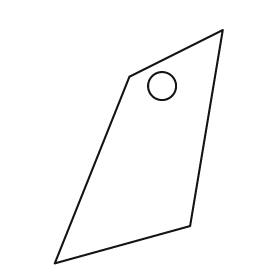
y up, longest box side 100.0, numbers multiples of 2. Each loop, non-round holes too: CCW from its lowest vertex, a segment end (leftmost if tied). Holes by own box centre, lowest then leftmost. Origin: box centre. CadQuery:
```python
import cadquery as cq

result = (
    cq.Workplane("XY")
    .moveTo(-36.0, -50.0)
    .lineTo(22.0, -34.0)
    .lineTo(36.0, 50.0)
    .lineTo(-4.0, 30.0)
    .close()
    .moveTo(10.0, 26.0)
    .circle(6.0)
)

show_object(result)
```